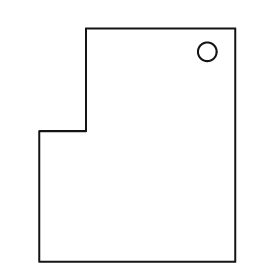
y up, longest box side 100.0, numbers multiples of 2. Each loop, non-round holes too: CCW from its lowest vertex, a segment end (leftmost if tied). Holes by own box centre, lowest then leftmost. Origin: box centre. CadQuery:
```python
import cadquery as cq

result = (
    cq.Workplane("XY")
    .moveTo(-42.0, -50.0)
    .lineTo(42.0, -50.0)
    .lineTo(42.0, 50.0)
    .lineTo(-22.0, 50.0)
    .lineTo(-22.0, 6.0)
    .lineTo(-42.0, 6.0)
    .close()
    .moveTo(30.0, 40.0)
    .circle(4.0)
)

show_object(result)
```